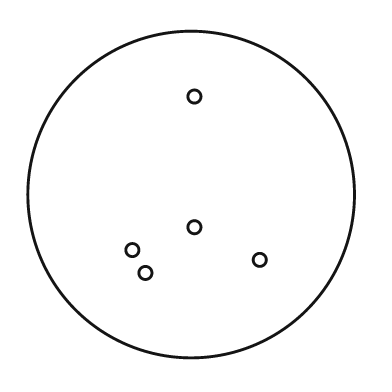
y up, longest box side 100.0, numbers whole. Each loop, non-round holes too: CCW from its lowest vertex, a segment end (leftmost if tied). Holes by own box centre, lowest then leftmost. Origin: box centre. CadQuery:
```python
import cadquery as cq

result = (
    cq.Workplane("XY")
    .moveTo(0.0, 0.0)
    .circle(50.0)
    .moveTo(-14.0, -24.0)
    .circle(2.0)
    .moveTo(21.0, -20.0)
    .circle(2.0)
    .moveTo(-18.0, -17.0)
    .circle(2.0)
    .moveTo(1.0, -10.0)
    .circle(2.0)
    .moveTo(1.0, 30.0)
    .circle(2.0)
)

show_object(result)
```